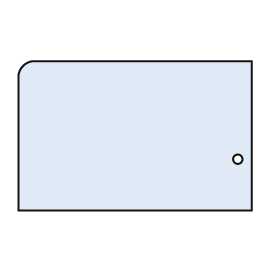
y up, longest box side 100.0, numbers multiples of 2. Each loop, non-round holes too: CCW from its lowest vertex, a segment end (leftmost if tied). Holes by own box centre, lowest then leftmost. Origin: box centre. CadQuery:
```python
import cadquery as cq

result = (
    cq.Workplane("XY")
    .moveTo(-50.0, -32.0)
    .lineTo(50.0, -32.0)
    .lineTo(50.0, 32.0)
    .lineTo(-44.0, 32.0)
    .threePointArc((-48.0, 30.0), (-50.0, 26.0))
    .close()
    .moveTo(44.0, -10.0)
    .circle(2.0)
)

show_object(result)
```